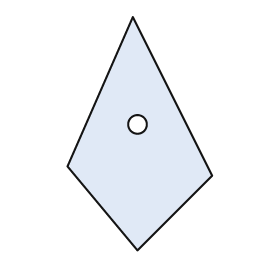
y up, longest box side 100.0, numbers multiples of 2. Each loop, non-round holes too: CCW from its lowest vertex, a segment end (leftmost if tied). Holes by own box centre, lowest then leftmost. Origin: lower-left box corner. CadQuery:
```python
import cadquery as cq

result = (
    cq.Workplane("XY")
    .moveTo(30.0, 0.0)
    .lineTo(62.0, 32.0)
    .lineTo(28.0, 100.0)
    .lineTo(0.0, 36.0)
    .close()
    .moveTo(30.0, 54.0)
    .circle(4.0)
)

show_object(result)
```